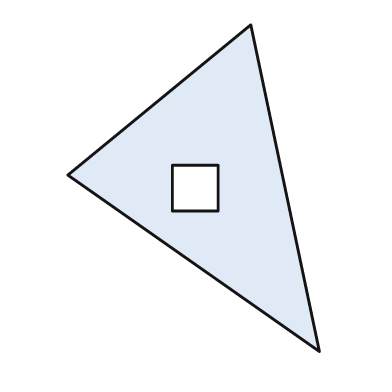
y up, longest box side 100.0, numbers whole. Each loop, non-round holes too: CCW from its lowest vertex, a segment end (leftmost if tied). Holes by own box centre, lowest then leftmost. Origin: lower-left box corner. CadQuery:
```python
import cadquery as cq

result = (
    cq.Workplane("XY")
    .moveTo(77.0, 0.0)
    .lineTo(56.0, 100.0)
    .lineTo(0.0, 54.0)
    .close()
    .moveTo(32.0, 43.0)
    .lineTo(46.0, 43.0)
    .lineTo(46.0, 57.0)
    .lineTo(32.0, 57.0)
    .close()
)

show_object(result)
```